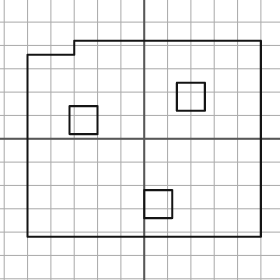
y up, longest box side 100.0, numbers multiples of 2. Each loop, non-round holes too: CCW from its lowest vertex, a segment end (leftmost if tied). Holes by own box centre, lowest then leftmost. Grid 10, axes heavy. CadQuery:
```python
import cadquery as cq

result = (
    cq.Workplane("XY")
    .moveTo(-50.0, -42.0)
    .lineTo(50.0, -42.0)
    .lineTo(50.0, 42.0)
    .lineTo(-30.0, 42.0)
    .lineTo(-30.0, 36.0)
    .lineTo(-50.0, 36.0)
    .close()
    .moveTo(0.0, -34.0)
    .lineTo(12.0, -34.0)
    .lineTo(12.0, -22.0)
    .lineTo(0.0, -22.0)
    .close()
    .moveTo(-32.0, 2.0)
    .lineTo(-20.0, 2.0)
    .lineTo(-20.0, 14.0)
    .lineTo(-32.0, 14.0)
    .close()
    .moveTo(14.0, 12.0)
    .lineTo(26.0, 12.0)
    .lineTo(26.0, 24.0)
    .lineTo(14.0, 24.0)
    .close()
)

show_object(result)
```